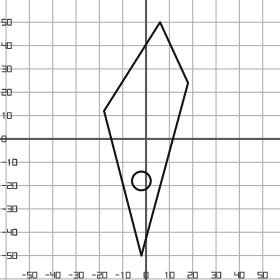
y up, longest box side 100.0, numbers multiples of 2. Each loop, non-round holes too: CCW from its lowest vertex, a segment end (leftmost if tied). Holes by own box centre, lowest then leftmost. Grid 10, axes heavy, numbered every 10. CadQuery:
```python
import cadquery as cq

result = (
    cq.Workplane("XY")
    .moveTo(-2.0, -50.0)
    .lineTo(18.0, 24.0)
    .lineTo(6.0, 50.0)
    .lineTo(-18.0, 12.0)
    .close()
    .moveTo(-2.0, -18.0)
    .circle(4.0)
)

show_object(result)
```